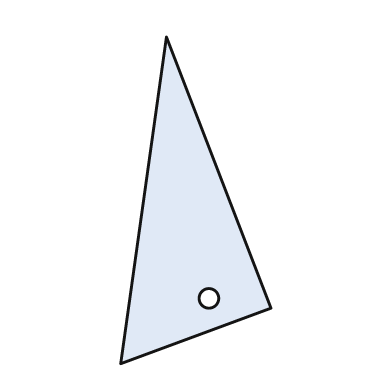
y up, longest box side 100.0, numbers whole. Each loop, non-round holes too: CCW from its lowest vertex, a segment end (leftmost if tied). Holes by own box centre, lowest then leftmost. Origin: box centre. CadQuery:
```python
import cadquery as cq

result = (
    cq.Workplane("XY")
    .moveTo(-23.0, -50.0)
    .lineTo(23.0, -33.0)
    .lineTo(-9.0, 50.0)
    .close()
    .moveTo(4.0, -30.0)
    .circle(3.0)
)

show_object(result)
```